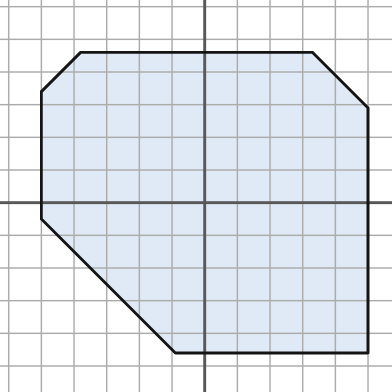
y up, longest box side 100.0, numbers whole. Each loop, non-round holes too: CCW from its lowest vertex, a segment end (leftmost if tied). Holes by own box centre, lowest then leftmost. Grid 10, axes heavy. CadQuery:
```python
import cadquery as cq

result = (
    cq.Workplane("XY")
    .moveTo(-9.0, -46.0)
    .lineTo(50.0, -46.0)
    .lineTo(50.0, 29.0)
    .lineTo(33.0, 46.0)
    .lineTo(-38.0, 46.0)
    .lineTo(-50.0, 34.0)
    .lineTo(-50.0, -5.0)
    .close()
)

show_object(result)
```